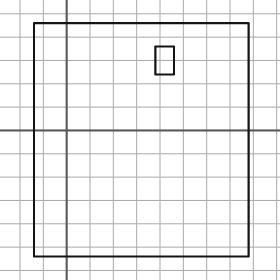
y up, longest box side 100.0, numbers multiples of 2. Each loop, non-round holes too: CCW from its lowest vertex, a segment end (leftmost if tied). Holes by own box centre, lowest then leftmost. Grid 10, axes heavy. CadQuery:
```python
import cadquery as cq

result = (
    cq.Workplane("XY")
    .moveTo(-14.0, -54.0)
    .lineTo(78.0, -54.0)
    .lineTo(78.0, 46.0)
    .lineTo(-14.0, 46.0)
    .close()
    .moveTo(38.0, 24.0)
    .lineTo(46.0, 24.0)
    .lineTo(46.0, 36.0)
    .lineTo(38.0, 36.0)
    .close()
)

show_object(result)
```